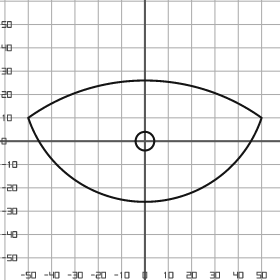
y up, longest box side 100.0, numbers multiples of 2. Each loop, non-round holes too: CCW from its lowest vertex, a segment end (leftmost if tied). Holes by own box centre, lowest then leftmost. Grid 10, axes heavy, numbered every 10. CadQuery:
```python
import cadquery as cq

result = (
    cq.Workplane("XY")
    .moveTo(-50.0, 10.0)
    .threePointArc((0.0, -26.0), (50.0, 10.0))
    .threePointArc((0.0, 26.0), (-50.0, 10.0))
    .close()
    .moveTo(0.0, 0.0)
    .circle(4.0)
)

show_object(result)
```